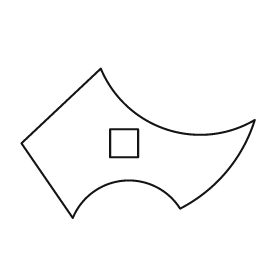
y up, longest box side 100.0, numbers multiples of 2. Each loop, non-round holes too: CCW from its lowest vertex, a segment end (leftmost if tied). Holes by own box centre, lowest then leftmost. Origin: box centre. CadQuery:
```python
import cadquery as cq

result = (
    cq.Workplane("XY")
    .moveTo(-28.0, -32.0)
    .threePointArc((-6.0, -16.0), (18.0, -28.0))
    .threePointArc((38.0, -12.0), (50.0, 10.0))
    .threePointArc((12.0, 6.0), (-16.0, 32.0))
    .lineTo(-50.0, 0.0)
    .close()
    .moveTo(-12.0, -6.0)
    .lineTo(0.0, -6.0)
    .lineTo(0.0, 6.0)
    .lineTo(-12.0, 6.0)
    .close()
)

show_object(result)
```